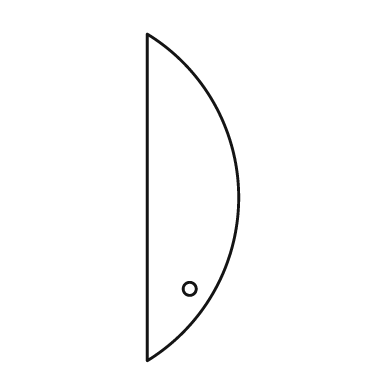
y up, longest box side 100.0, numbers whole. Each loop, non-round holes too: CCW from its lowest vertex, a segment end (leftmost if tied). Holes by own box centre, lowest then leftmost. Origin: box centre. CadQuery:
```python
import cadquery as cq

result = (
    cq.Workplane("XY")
    .moveTo(-14.0, -50.0)
    .threePointArc((14.0, 0.0), (-14.0, 50.0))
    .close()
    .moveTo(-1.0, -28.0)
    .circle(2.0)
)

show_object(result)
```